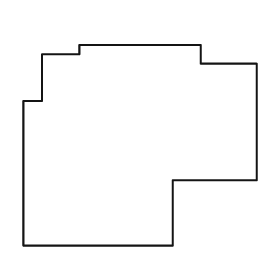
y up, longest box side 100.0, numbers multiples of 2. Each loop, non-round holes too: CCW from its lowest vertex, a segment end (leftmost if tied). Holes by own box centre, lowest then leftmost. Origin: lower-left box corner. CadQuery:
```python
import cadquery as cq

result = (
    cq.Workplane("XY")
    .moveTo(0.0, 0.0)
    .lineTo(64.0, 0.0)
    .lineTo(64.0, 28.0)
    .lineTo(100.0, 28.0)
    .lineTo(100.0, 78.0)
    .lineTo(76.0, 78.0)
    .lineTo(76.0, 86.0)
    .lineTo(24.0, 86.0)
    .lineTo(24.0, 82.0)
    .lineTo(8.0, 82.0)
    .lineTo(8.0, 62.0)
    .lineTo(0.0, 62.0)
    .close()
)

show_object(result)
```